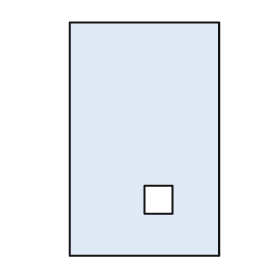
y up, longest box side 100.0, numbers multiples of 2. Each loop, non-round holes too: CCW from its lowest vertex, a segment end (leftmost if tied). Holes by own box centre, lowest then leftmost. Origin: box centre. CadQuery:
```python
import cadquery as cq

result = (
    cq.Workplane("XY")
    .moveTo(-32.0, -50.0)
    .lineTo(32.0, -50.0)
    .lineTo(32.0, 50.0)
    .lineTo(-32.0, 50.0)
    .close()
    .moveTo(0.0, -32.0)
    .lineTo(12.0, -32.0)
    .lineTo(12.0, -20.0)
    .lineTo(0.0, -20.0)
    .close()
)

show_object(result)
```